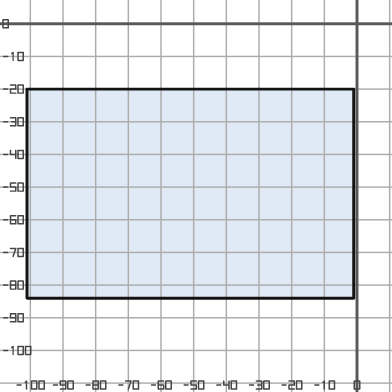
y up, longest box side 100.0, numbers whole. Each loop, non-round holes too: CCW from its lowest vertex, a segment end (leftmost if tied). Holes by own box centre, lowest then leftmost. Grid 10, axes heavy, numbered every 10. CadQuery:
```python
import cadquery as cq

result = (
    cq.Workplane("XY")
    .moveTo(-101.0, -84.0)
    .lineTo(-1.0, -84.0)
    .lineTo(-1.0, -20.0)
    .lineTo(-101.0, -20.0)
    .close()
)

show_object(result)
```